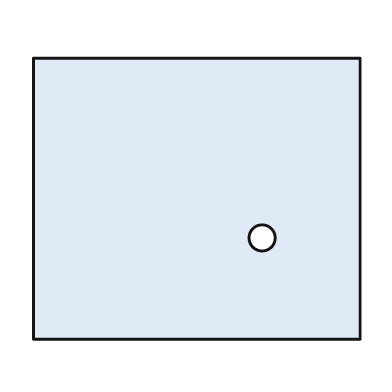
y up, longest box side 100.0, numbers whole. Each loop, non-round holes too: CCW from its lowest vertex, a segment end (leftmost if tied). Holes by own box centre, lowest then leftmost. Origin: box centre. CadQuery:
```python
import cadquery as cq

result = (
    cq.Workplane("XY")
    .moveTo(-50.0, -43.0)
    .lineTo(50.0, -43.0)
    .lineTo(50.0, 43.0)
    .lineTo(-50.0, 43.0)
    .close()
    .moveTo(20.0, -12.0)
    .circle(4.0)
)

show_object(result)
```